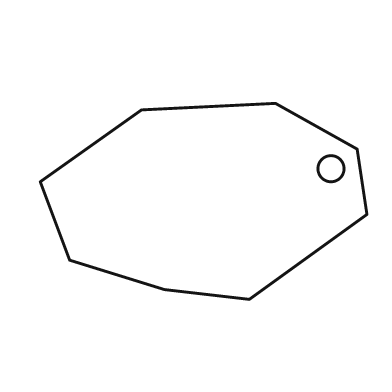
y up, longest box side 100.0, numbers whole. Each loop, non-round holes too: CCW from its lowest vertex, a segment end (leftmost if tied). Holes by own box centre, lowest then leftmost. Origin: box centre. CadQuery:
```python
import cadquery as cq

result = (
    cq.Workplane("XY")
    .moveTo(14.0, -30.0)
    .lineTo(50.0, -4.0)
    .lineTo(47.0, 16.0)
    .lineTo(22.0, 30.0)
    .lineTo(-19.0, 28.0)
    .lineTo(-50.0, 6.0)
    .lineTo(-41.0, -18.0)
    .lineTo(-12.0, -27.0)
    .close()
    .moveTo(39.0, 10.0)
    .circle(4.0)
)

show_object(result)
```